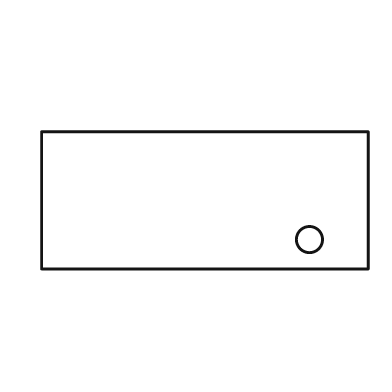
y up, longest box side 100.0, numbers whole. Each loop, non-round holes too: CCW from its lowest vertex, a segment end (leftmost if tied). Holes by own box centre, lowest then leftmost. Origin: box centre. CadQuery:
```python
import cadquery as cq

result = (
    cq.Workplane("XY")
    .moveTo(-50.0, -21.0)
    .lineTo(50.0, -21.0)
    .lineTo(50.0, 21.0)
    .lineTo(-50.0, 21.0)
    .close()
    .moveTo(32.0, -12.0)
    .circle(4.0)
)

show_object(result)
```